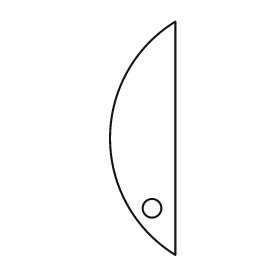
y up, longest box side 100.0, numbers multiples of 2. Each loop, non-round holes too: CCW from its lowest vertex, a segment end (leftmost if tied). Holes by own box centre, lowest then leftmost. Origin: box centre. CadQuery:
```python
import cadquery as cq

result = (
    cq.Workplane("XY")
    .moveTo(14.0, -50.0)
    .lineTo(14.0, 50.0)
    .threePointArc((-14.0, 0.0), (14.0, -50.0))
    .close()
    .moveTo(4.0, -30.0)
    .circle(4.0)
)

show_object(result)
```